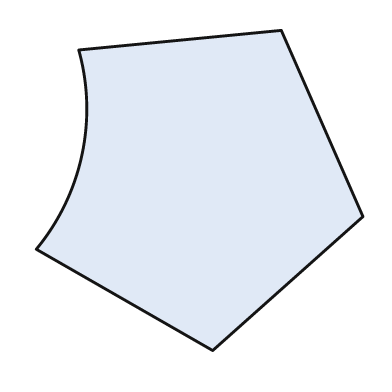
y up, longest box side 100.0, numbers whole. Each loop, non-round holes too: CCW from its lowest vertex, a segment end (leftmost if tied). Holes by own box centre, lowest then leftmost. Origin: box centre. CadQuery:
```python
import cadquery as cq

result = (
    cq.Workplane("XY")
    .moveTo(4.0, -49.0)
    .lineTo(50.0, -8.0)
    .lineTo(25.0, 49.0)
    .lineTo(-37.0, 43.0)
    .threePointArc((-36.0, 11.0), (-50.0, -18.0))
    .close()
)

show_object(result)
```